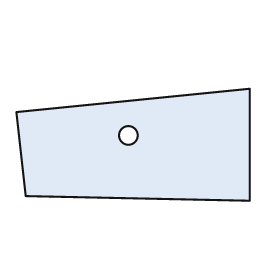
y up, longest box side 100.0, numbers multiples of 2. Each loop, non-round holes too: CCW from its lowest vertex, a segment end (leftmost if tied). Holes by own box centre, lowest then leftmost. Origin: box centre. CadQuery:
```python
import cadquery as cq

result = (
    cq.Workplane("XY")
    .moveTo(50.0, -24.0)
    .lineTo(50.0, 24.0)
    .lineTo(-50.0, 14.0)
    .lineTo(-46.0, -22.0)
    .close()
    .moveTo(-2.0, 4.0)
    .circle(4.0)
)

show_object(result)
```